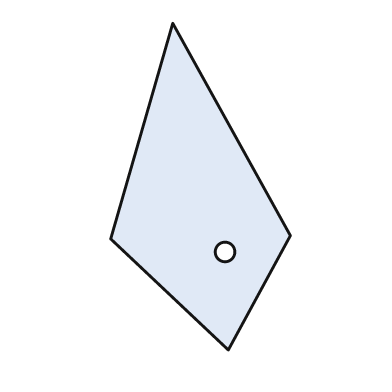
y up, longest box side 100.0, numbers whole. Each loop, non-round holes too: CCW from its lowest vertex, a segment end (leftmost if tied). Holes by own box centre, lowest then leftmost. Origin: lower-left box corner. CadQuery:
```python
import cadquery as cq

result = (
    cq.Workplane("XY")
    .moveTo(36.0, 0.0)
    .lineTo(55.0, 35.0)
    .lineTo(19.0, 100.0)
    .lineTo(0.0, 34.0)
    .close()
    .moveTo(35.0, 30.0)
    .circle(3.0)
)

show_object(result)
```